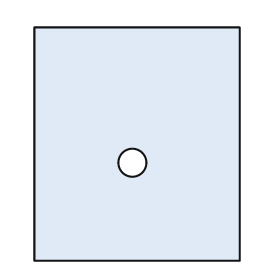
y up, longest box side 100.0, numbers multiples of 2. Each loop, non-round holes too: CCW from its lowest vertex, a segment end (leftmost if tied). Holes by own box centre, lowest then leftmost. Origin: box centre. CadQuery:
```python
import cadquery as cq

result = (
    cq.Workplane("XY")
    .moveTo(-44.0, -50.0)
    .lineTo(44.0, -50.0)
    .lineTo(44.0, 50.0)
    .lineTo(-44.0, 50.0)
    .close()
    .moveTo(-2.0, -8.0)
    .circle(6.0)
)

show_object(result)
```